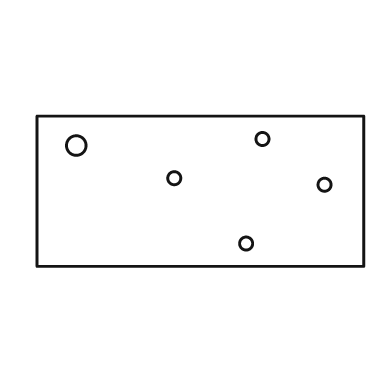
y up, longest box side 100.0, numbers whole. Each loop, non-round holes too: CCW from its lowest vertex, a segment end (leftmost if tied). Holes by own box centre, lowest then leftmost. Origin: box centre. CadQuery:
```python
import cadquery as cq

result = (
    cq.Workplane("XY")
    .moveTo(-50.0, -23.0)
    .lineTo(50.0, -23.0)
    .lineTo(50.0, 23.0)
    .lineTo(-50.0, 23.0)
    .close()
    .moveTo(14.0, -16.0)
    .circle(2.0)
    .moveTo(38.0, 2.0)
    .circle(2.0)
    .moveTo(-8.0, 4.0)
    .circle(2.0)
    .moveTo(-38.0, 14.0)
    .circle(3.0)
    .moveTo(19.0, 16.0)
    .circle(2.0)
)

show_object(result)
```